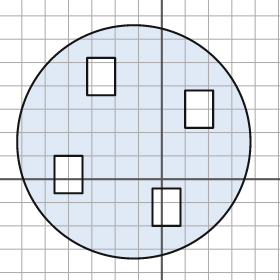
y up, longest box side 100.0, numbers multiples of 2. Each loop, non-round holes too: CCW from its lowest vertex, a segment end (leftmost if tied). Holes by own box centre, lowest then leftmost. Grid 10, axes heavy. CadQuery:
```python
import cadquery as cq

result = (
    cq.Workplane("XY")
    .moveTo(-12.0, 16.0)
    .circle(50.0)
    .moveTo(-4.0, -20.0)
    .lineTo(8.0, -20.0)
    .lineTo(8.0, -4.0)
    .lineTo(-4.0, -4.0)
    .close()
    .moveTo(-46.0, -6.0)
    .lineTo(-34.0, -6.0)
    .lineTo(-34.0, 10.0)
    .lineTo(-46.0, 10.0)
    .close()
    .moveTo(10.0, 22.0)
    .lineTo(22.0, 22.0)
    .lineTo(22.0, 38.0)
    .lineTo(10.0, 38.0)
    .close()
    .moveTo(-32.0, 36.0)
    .lineTo(-20.0, 36.0)
    .lineTo(-20.0, 52.0)
    .lineTo(-32.0, 52.0)
    .close()
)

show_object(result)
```